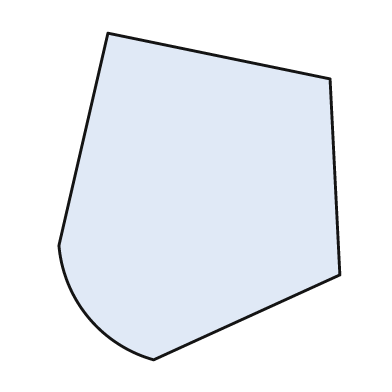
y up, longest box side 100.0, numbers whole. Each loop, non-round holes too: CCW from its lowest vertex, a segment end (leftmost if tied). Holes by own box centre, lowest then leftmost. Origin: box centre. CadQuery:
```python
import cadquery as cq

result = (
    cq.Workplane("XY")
    .moveTo(-14.0, -50.0)
    .lineTo(43.0, -24.0)
    .lineTo(40.0, 36.0)
    .lineTo(-28.0, 50.0)
    .lineTo(-43.0, -15.0)
    .threePointArc((-34.0, -37.0), (-14.0, -50.0))
    .close()
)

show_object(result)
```